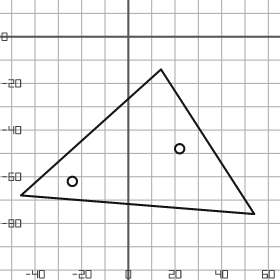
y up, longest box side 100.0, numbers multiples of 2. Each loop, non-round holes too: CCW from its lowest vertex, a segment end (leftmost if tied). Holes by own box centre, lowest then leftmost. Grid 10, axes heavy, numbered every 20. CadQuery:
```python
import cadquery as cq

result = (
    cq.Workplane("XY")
    .moveTo(54.0, -76.0)
    .lineTo(14.0, -14.0)
    .lineTo(-46.0, -68.0)
    .close()
    .moveTo(-24.0, -62.0)
    .circle(2.0)
    .moveTo(22.0, -48.0)
    .circle(2.0)
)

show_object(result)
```